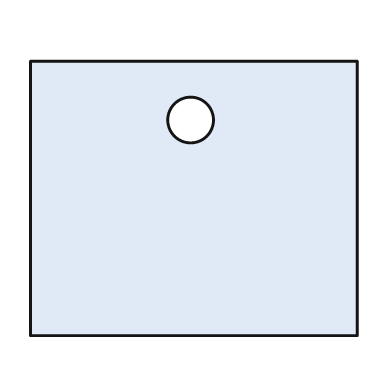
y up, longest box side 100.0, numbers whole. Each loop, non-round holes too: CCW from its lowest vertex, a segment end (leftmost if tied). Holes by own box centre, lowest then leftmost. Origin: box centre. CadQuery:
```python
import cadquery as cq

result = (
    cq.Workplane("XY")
    .moveTo(-50.0, -42.0)
    .lineTo(50.0, -42.0)
    .lineTo(50.0, 42.0)
    .lineTo(-50.0, 42.0)
    .close()
    .moveTo(-1.0, 24.0)
    .circle(7.0)
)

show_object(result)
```